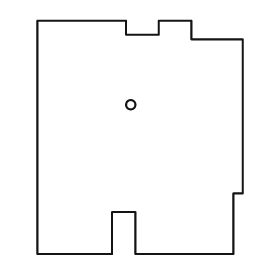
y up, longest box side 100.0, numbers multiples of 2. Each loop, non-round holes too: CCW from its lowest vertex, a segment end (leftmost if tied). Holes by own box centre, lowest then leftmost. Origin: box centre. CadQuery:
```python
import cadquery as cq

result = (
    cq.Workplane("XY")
    .moveTo(-44.0, -50.0)
    .lineTo(-12.0, -50.0)
    .lineTo(-12.0, -32.0)
    .lineTo(-2.0, -32.0)
    .lineTo(-2.0, -50.0)
    .lineTo(40.0, -50.0)
    .lineTo(40.0, -24.0)
    .lineTo(44.0, -24.0)
    .lineTo(44.0, 42.0)
    .lineTo(22.0, 42.0)
    .lineTo(22.0, 50.0)
    .lineTo(8.0, 50.0)
    .lineTo(8.0, 44.0)
    .lineTo(-6.0, 44.0)
    .lineTo(-6.0, 50.0)
    .lineTo(-44.0, 50.0)
    .close()
    .moveTo(-4.0, 14.0)
    .circle(2.0)
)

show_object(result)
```